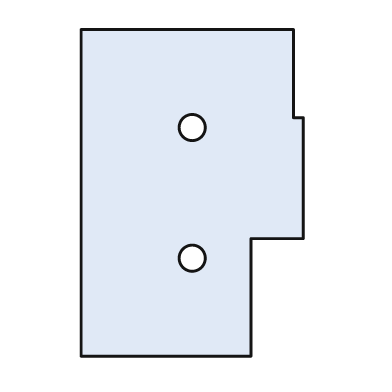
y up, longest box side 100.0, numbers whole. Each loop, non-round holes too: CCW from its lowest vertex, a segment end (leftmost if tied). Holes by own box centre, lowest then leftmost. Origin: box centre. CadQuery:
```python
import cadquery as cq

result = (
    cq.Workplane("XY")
    .moveTo(-34.0, -50.0)
    .lineTo(18.0, -50.0)
    .lineTo(18.0, -14.0)
    .lineTo(34.0, -14.0)
    .lineTo(34.0, 23.0)
    .lineTo(31.0, 23.0)
    .lineTo(31.0, 50.0)
    .lineTo(-34.0, 50.0)
    .close()
    .moveTo(0.0, -20.0)
    .circle(4.0)
    .moveTo(0.0, 20.0)
    .circle(4.0)
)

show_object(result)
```